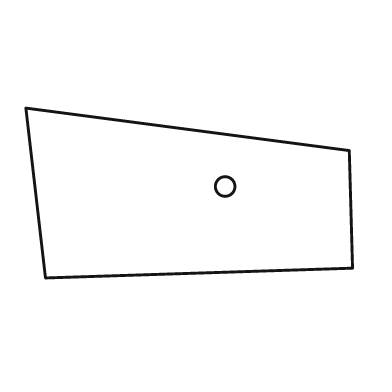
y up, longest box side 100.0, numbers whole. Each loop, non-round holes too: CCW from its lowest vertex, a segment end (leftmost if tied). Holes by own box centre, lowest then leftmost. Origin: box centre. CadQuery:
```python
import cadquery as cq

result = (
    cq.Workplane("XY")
    .moveTo(-44.0, -26.0)
    .lineTo(50.0, -23.0)
    .lineTo(49.0, 13.0)
    .lineTo(-50.0, 26.0)
    .close()
    .moveTo(11.0, 2.0)
    .circle(3.0)
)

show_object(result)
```